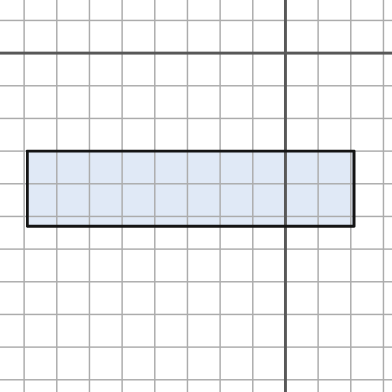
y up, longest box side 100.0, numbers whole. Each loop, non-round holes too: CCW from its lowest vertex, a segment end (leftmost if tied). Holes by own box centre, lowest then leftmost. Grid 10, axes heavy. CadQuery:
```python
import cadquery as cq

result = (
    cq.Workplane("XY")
    .moveTo(-79.0, -53.0)
    .lineTo(21.0, -53.0)
    .lineTo(21.0, -30.0)
    .lineTo(-79.0, -30.0)
    .close()
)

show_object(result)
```